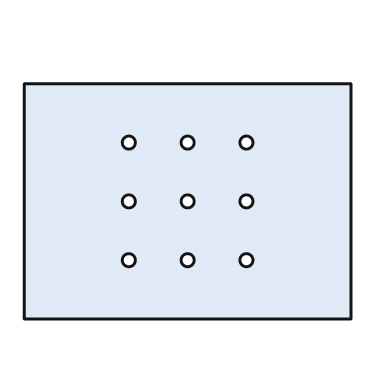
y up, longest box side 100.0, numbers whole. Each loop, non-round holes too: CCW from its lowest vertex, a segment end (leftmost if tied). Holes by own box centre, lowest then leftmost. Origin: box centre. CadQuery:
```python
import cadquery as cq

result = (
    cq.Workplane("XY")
    .moveTo(-50.0, -36.0)
    .lineTo(50.0, -36.0)
    .lineTo(50.0, 36.0)
    .lineTo(-50.0, 36.0)
    .close()
    .moveTo(-18.0, -18.0)
    .circle(2.0)
    .moveTo(0.0, -18.0)
    .circle(2.0)
    .moveTo(18.0, -18.0)
    .circle(2.0)
    .moveTo(-18.0, 0.0)
    .circle(2.0)
    .moveTo(0.0, 0.0)
    .circle(2.0)
    .moveTo(18.0, 0.0)
    .circle(2.0)
    .moveTo(-18.0, 18.0)
    .circle(2.0)
    .moveTo(0.0, 18.0)
    .circle(2.0)
    .moveTo(18.0, 18.0)
    .circle(2.0)
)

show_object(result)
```